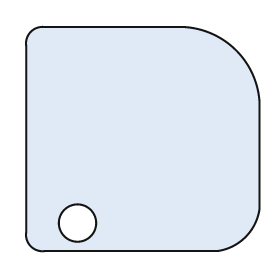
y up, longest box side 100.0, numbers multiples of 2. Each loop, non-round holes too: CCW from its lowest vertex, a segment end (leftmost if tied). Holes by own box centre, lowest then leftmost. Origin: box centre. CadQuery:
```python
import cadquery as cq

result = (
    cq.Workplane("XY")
    .moveTo(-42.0, -48.0)
    .lineTo(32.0, -48.0)
    .threePointArc((44.0, -42.0), (50.0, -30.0))
    .lineTo(50.0, 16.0)
    .threePointArc((40.0, 38.0), (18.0, 48.0))
    .lineTo(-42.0, 48.0)
    .threePointArc((-48.0, 46.0), (-50.0, 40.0))
    .lineTo(-50.0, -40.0)
    .threePointArc((-48.0, -46.0), (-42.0, -48.0))
    .close()
    .moveTo(-28.0, -36.0)
    .circle(8.0)
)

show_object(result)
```